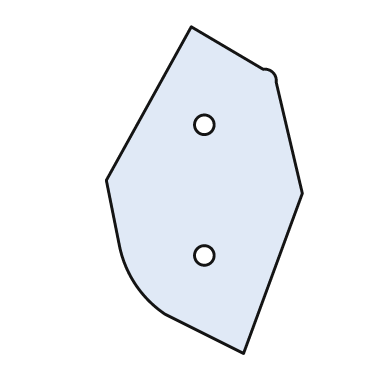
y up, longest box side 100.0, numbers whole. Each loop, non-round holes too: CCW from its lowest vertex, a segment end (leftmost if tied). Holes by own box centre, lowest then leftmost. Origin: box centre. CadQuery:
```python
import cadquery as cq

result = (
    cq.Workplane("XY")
    .moveTo(12.0, -50.0)
    .lineTo(30.0, -1.0)
    .lineTo(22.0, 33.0)
    .threePointArc((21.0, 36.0), (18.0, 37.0))
    .lineTo(-4.0, 50.0)
    .lineTo(-30.0, 3.0)
    .lineTo(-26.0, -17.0)
    .threePointArc((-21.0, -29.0), (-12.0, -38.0))
    .close()
    .moveTo(0.0, -20.0)
    .circle(3.0)
    .moveTo(0.0, 20.0)
    .circle(3.0)
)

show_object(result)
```